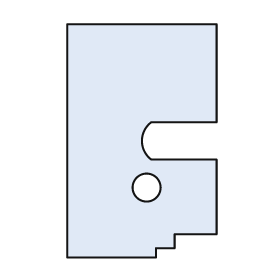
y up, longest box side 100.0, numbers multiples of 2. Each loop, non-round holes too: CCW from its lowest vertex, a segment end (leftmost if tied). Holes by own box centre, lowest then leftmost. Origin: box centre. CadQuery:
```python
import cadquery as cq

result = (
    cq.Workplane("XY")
    .moveTo(-32.0, -50.0)
    .lineTo(6.0, -50.0)
    .lineTo(6.0, -46.0)
    .lineTo(14.0, -46.0)
    .lineTo(14.0, -40.0)
    .lineTo(32.0, -40.0)
    .lineTo(32.0, -8.0)
    .lineTo(4.0, -8.0)
    .threePointArc((0.0, 0.0), (4.0, 8.0))
    .lineTo(32.0, 8.0)
    .lineTo(32.0, 50.0)
    .lineTo(-32.0, 50.0)
    .close()
    .moveTo(2.0, -20.0)
    .circle(6.0)
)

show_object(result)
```